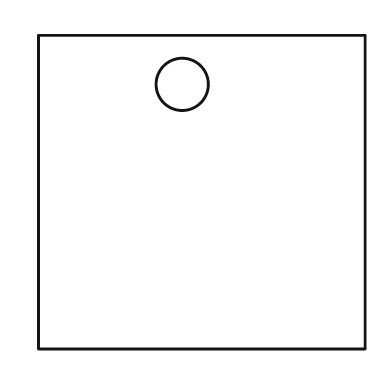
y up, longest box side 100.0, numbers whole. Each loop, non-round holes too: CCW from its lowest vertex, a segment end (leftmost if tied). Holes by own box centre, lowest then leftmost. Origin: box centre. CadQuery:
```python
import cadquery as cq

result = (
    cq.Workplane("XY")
    .moveTo(-50.0, -48.0)
    .lineTo(50.0, -48.0)
    .lineTo(50.0, 48.0)
    .lineTo(-50.0, 48.0)
    .close()
    .moveTo(-6.0, 33.0)
    .circle(8.0)
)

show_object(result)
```